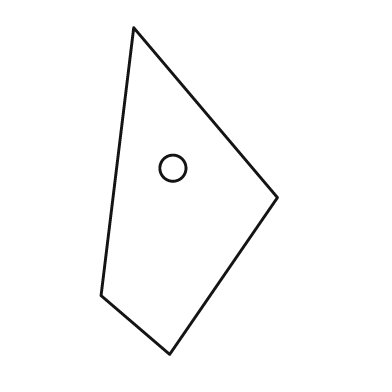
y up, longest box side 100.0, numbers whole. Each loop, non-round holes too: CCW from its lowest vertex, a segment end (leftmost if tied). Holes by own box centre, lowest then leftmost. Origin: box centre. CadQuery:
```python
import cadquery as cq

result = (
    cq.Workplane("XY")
    .moveTo(-6.0, -50.0)
    .lineTo(27.0, -2.0)
    .lineTo(-17.0, 50.0)
    .lineTo(-27.0, -32.0)
    .close()
    .moveTo(-5.0, 7.0)
    .circle(4.0)
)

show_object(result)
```